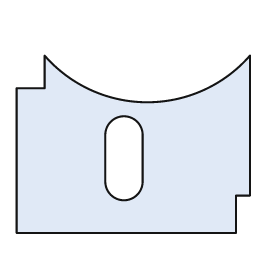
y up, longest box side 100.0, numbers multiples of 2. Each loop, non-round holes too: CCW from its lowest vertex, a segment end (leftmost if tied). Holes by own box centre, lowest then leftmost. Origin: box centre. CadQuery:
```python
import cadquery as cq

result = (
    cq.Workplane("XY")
    .moveTo(-50.0, -38.0)
    .lineTo(44.0, -38.0)
    .lineTo(44.0, -22.0)
    .lineTo(50.0, -22.0)
    .lineTo(50.0, 38.0)
    .threePointArc((6.0, 18.0), (-38.0, 38.0))
    .lineTo(-38.0, 24.0)
    .lineTo(-50.0, 24.0)
    .close()
    .moveTo(-12.0, -16.0)
    .threePointArc((-4.0, -24.0), (4.0, -16.0))
    .lineTo(4.0, 4.0)
    .threePointArc((-4.0, 12.0), (-12.0, 4.0))
    .close()
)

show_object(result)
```